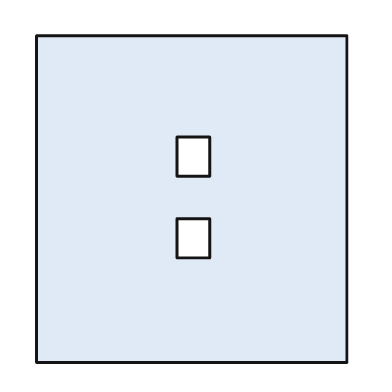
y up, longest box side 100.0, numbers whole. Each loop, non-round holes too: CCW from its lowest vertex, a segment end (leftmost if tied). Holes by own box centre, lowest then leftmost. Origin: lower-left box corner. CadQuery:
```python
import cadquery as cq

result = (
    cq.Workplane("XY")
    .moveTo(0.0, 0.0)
    .lineTo(95.0, 0.0)
    .lineTo(95.0, 100.0)
    .lineTo(0.0, 100.0)
    .close()
    .moveTo(43.0, 32.0)
    .lineTo(53.0, 32.0)
    .lineTo(53.0, 44.0)
    .lineTo(43.0, 44.0)
    .close()
    .moveTo(43.0, 57.0)
    .lineTo(53.0, 57.0)
    .lineTo(53.0, 69.0)
    .lineTo(43.0, 69.0)
    .close()
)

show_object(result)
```